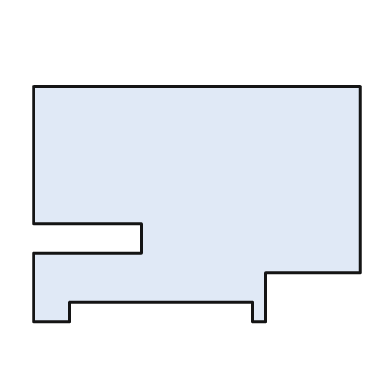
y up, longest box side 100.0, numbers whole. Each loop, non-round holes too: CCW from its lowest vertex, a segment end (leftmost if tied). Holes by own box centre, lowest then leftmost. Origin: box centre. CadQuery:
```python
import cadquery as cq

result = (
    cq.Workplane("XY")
    .moveTo(-50.0, -36.0)
    .lineTo(-39.0, -36.0)
    .lineTo(-39.0, -30.0)
    .lineTo(17.0, -30.0)
    .lineTo(17.0, -36.0)
    .lineTo(21.0, -36.0)
    .lineTo(21.0, -21.0)
    .lineTo(50.0, -21.0)
    .lineTo(50.0, 36.0)
    .lineTo(-50.0, 36.0)
    .lineTo(-50.0, -6.0)
    .lineTo(-17.0, -6.0)
    .lineTo(-17.0, -15.0)
    .lineTo(-50.0, -15.0)
    .close()
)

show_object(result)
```